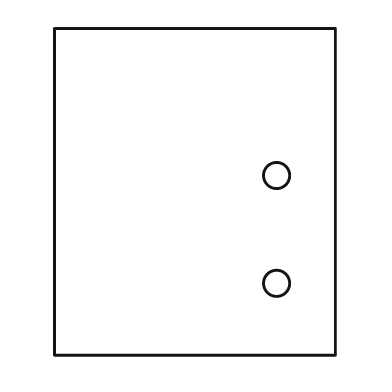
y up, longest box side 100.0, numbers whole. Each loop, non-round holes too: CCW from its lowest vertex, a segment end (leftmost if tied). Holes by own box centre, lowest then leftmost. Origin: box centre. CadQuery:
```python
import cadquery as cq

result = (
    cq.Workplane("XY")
    .moveTo(-43.0, -50.0)
    .lineTo(43.0, -50.0)
    .lineTo(43.0, 50.0)
    .lineTo(-43.0, 50.0)
    .close()
    .moveTo(25.0, -28.0)
    .circle(4.0)
    .moveTo(25.0, 5.0)
    .circle(4.0)
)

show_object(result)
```